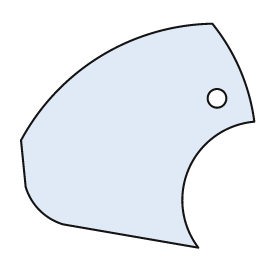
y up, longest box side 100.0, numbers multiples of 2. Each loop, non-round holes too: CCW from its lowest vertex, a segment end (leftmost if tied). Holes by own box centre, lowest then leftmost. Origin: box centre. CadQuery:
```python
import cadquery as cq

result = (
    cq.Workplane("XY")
    .moveTo(26.0, -48.0)
    .threePointArc((22.0, -14.0), (50.0, 6.0))
    .threePointArc((44.0, 28.0), (32.0, 48.0))
    .threePointArc((-16.0, 34.0), (-50.0, -2.0))
    .lineTo(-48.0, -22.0)
    .threePointArc((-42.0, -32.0), (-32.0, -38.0))
    .close()
    .moveTo(34.0, 16.0)
    .circle(4.0)
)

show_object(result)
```